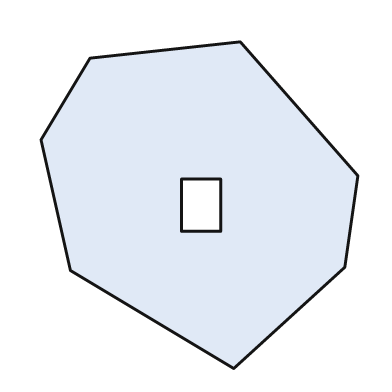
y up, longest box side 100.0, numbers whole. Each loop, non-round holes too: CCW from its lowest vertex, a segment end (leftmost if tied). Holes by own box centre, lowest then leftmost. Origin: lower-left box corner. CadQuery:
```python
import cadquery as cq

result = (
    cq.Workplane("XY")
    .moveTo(59.0, 0.0)
    .lineTo(93.0, 31.0)
    .lineTo(97.0, 59.0)
    .lineTo(61.0, 100.0)
    .lineTo(15.0, 95.0)
    .lineTo(0.0, 70.0)
    .lineTo(9.0, 30.0)
    .close()
    .moveTo(43.0, 42.0)
    .lineTo(55.0, 42.0)
    .lineTo(55.0, 58.0)
    .lineTo(43.0, 58.0)
    .close()
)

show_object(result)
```